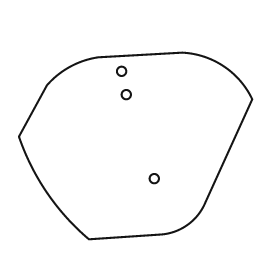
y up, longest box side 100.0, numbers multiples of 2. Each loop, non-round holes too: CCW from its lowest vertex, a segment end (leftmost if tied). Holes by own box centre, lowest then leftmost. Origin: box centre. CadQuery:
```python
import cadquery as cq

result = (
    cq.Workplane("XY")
    .moveTo(-20.0, -40.0)
    .lineTo(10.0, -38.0)
    .threePointArc((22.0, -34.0), (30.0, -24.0))
    .lineTo(50.0, 20.0)
    .threePointArc((38.0, 34.0), (20.0, 40.0))
    .lineTo(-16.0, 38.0)
    .threePointArc((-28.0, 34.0), (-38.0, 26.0))
    .lineTo(-50.0, 4.0)
    .threePointArc((-38.0, -20.0), (-20.0, -40.0))
    .close()
    .moveTo(8.0, -14.0)
    .circle(2.0)
    .moveTo(-4.0, 22.0)
    .circle(2.0)
    .moveTo(-6.0, 32.0)
    .circle(2.0)
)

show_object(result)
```